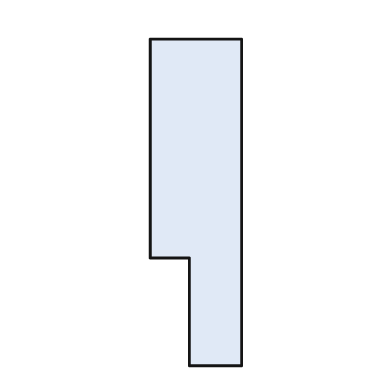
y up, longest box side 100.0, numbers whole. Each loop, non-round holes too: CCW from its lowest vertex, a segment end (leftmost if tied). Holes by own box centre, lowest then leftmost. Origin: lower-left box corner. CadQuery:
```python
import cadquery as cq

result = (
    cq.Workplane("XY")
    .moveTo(12.0, 0.0)
    .lineTo(28.0, 0.0)
    .lineTo(28.0, 100.0)
    .lineTo(0.0, 100.0)
    .lineTo(0.0, 33.0)
    .lineTo(12.0, 33.0)
    .close()
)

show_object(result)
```